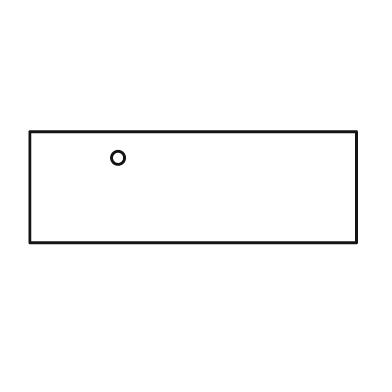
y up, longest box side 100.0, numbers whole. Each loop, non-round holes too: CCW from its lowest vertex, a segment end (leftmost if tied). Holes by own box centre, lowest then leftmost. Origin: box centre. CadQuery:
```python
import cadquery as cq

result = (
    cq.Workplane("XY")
    .moveTo(-50.0, -17.0)
    .lineTo(50.0, -17.0)
    .lineTo(50.0, 17.0)
    .lineTo(-50.0, 17.0)
    .close()
    .moveTo(-23.0, 9.0)
    .circle(2.0)
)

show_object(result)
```